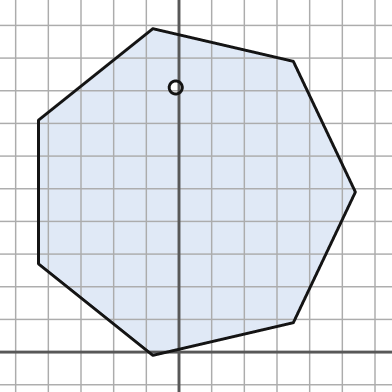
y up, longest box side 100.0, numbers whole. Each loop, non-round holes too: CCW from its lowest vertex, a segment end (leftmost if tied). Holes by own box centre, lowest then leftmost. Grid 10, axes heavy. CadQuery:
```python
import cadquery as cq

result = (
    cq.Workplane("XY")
    .moveTo(-8.0, -1.0)
    .lineTo(35.0, 9.0)
    .lineTo(54.0, 49.0)
    .lineTo(35.0, 89.0)
    .lineTo(-8.0, 99.0)
    .lineTo(-43.0, 71.0)
    .lineTo(-43.0, 27.0)
    .close()
    .moveTo(-1.0, 81.0)
    .circle(2.0)
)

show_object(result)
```